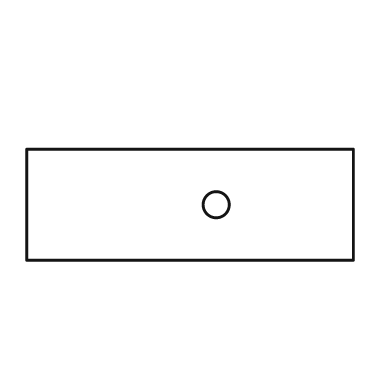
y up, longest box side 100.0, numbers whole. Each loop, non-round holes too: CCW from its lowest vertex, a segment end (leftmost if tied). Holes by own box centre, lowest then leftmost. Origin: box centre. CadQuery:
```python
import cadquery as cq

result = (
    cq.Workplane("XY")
    .moveTo(-50.0, -17.0)
    .lineTo(50.0, -17.0)
    .lineTo(50.0, 17.0)
    .lineTo(-50.0, 17.0)
    .close()
    .moveTo(8.0, 0.0)
    .circle(4.0)
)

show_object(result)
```